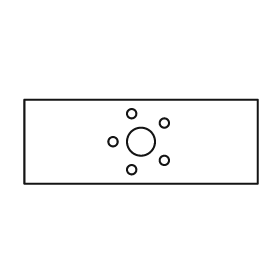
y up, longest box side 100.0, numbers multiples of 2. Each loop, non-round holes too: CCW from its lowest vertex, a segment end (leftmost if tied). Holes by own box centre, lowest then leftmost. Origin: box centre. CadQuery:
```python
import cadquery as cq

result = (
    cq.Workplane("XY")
    .moveTo(-50.0, -18.0)
    .lineTo(50.0, -18.0)
    .lineTo(50.0, 18.0)
    .lineTo(-50.0, 18.0)
    .close()
    .moveTo(-4.0, -12.0)
    .circle(2.0)
    .moveTo(10.0, -8.0)
    .circle(2.0)
    .moveTo(-12.0, 0.0)
    .circle(2.0)
    .moveTo(0.0, 0.0)
    .circle(6.0)
    .moveTo(10.0, 8.0)
    .circle(2.0)
    .moveTo(-4.0, 12.0)
    .circle(2.0)
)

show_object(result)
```